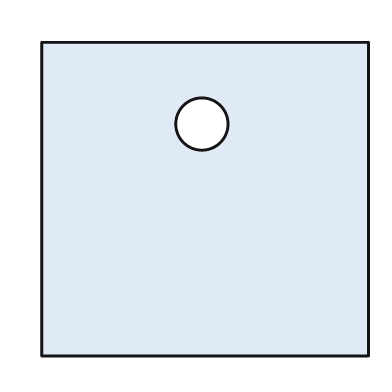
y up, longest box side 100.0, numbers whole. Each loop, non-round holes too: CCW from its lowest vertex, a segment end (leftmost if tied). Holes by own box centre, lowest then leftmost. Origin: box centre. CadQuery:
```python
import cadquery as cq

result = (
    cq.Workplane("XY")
    .moveTo(-50.0, -48.0)
    .lineTo(50.0, -48.0)
    .lineTo(50.0, 48.0)
    .lineTo(-50.0, 48.0)
    .close()
    .moveTo(-1.0, 23.0)
    .circle(8.0)
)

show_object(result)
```